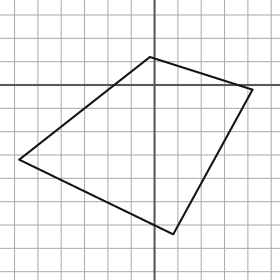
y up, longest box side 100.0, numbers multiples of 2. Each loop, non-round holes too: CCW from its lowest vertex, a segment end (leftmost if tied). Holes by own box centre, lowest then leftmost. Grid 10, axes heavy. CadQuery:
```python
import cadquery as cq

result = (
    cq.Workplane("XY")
    .moveTo(8.0, -64.0)
    .lineTo(42.0, -2.0)
    .lineTo(-2.0, 12.0)
    .lineTo(-58.0, -32.0)
    .close()
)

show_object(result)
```